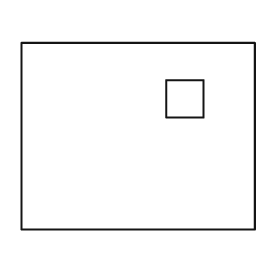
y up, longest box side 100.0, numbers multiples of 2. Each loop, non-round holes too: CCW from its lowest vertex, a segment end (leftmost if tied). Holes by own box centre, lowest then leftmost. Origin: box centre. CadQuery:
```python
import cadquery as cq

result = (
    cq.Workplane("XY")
    .moveTo(-50.0, -40.0)
    .lineTo(50.0, -40.0)
    .lineTo(50.0, 40.0)
    .lineTo(-50.0, 40.0)
    .close()
    .moveTo(12.0, 8.0)
    .lineTo(28.0, 8.0)
    .lineTo(28.0, 24.0)
    .lineTo(12.0, 24.0)
    .close()
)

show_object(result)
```